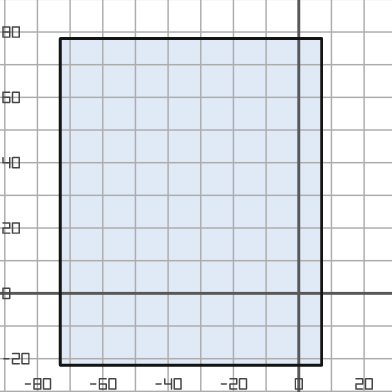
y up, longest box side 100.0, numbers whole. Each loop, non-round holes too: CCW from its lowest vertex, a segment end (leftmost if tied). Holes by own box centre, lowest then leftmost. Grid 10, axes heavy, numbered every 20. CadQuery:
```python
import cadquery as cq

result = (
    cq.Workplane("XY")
    .moveTo(-73.0, -22.0)
    .lineTo(7.0, -22.0)
    .lineTo(7.0, 78.0)
    .lineTo(-73.0, 78.0)
    .close()
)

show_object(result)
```